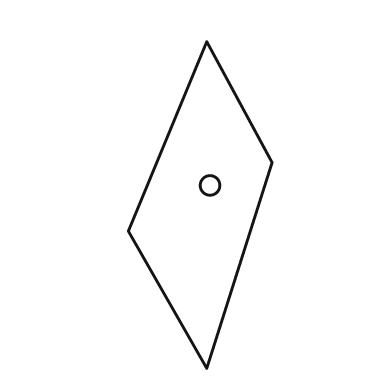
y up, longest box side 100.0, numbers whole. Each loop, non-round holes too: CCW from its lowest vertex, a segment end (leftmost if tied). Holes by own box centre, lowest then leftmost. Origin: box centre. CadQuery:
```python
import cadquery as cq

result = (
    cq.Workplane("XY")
    .moveTo(2.0, -50.0)
    .lineTo(22.0, 13.0)
    .lineTo(2.0, 50.0)
    .lineTo(-22.0, -8.0)
    .close()
    .moveTo(3.0, 6.0)
    .circle(3.0)
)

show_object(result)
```